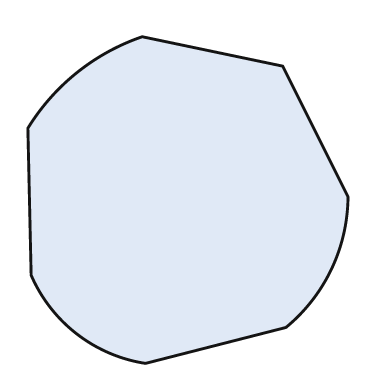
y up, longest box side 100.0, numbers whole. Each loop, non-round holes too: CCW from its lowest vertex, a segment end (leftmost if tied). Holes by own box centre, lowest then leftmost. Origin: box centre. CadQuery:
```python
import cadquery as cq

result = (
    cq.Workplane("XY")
    .moveTo(-13.0, -50.0)
    .lineTo(30.0, -39.0)
    .threePointArc((44.0, -21.0), (49.0, 1.0))
    .lineTo(29.0, 41.0)
    .lineTo(-14.0, 50.0)
    .threePointArc((-34.0, 39.0), (-49.0, 22.0))
    .lineTo(-48.0, -23.0)
    .threePointArc((-34.0, -41.0), (-13.0, -50.0))
    .close()
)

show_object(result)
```